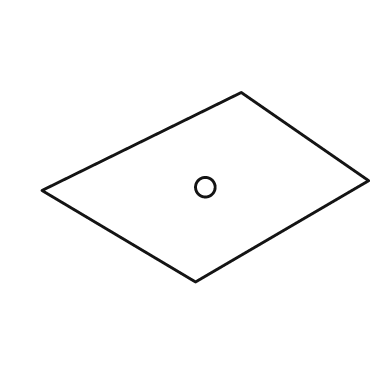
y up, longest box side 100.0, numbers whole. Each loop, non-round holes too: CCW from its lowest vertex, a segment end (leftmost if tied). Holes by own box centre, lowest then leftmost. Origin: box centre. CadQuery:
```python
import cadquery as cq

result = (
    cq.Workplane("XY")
    .moveTo(-3.0, -29.0)
    .lineTo(50.0, 2.0)
    .lineTo(11.0, 29.0)
    .lineTo(-50.0, -1.0)
    .close()
    .moveTo(0.0, 0.0)
    .circle(3.0)
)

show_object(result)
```